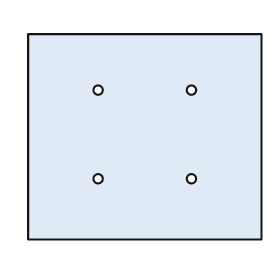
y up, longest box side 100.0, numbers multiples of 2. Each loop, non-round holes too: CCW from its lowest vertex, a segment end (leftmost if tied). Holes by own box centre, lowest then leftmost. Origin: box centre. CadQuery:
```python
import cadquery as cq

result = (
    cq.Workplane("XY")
    .moveTo(-50.0, -44.0)
    .lineTo(50.0, -44.0)
    .lineTo(50.0, 44.0)
    .lineTo(-50.0, 44.0)
    .close()
    .moveTo(-20.0, -18.0)
    .circle(2.0)
    .moveTo(20.0, -18.0)
    .circle(2.0)
    .moveTo(-20.0, 20.0)
    .circle(2.0)
    .moveTo(20.0, 20.0)
    .circle(2.0)
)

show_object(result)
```